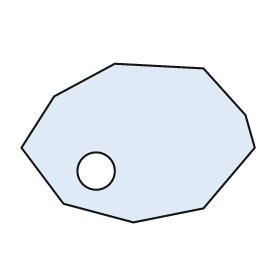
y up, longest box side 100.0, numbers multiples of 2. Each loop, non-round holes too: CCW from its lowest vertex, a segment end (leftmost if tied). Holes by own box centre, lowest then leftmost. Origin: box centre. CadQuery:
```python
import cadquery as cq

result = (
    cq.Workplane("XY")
    .moveTo(-2.0, -34.0)
    .lineTo(28.0, -28.0)
    .lineTo(50.0, -2.0)
    .lineTo(46.0, 12.0)
    .lineTo(28.0, 32.0)
    .lineTo(-10.0, 34.0)
    .lineTo(-36.0, 20.0)
    .lineTo(-50.0, -2.0)
    .lineTo(-32.0, -26.0)
    .close()
    .moveTo(-18.0, -12.0)
    .circle(8.0)
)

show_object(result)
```